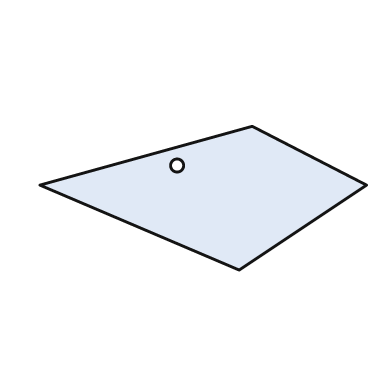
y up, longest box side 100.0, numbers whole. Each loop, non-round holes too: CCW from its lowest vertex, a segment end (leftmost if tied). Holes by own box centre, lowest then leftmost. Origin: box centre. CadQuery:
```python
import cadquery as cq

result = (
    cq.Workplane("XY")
    .moveTo(11.0, -22.0)
    .lineTo(50.0, 4.0)
    .lineTo(15.0, 22.0)
    .lineTo(-50.0, 4.0)
    .close()
    .moveTo(-8.0, 10.0)
    .circle(2.0)
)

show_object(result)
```